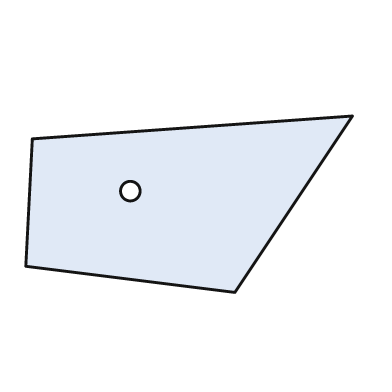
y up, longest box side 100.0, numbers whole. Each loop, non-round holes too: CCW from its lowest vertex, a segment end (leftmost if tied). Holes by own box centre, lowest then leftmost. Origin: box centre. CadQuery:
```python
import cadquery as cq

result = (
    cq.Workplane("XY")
    .moveTo(14.0, -27.0)
    .lineTo(50.0, 27.0)
    .lineTo(-48.0, 20.0)
    .lineTo(-50.0, -19.0)
    .close()
    .moveTo(-18.0, 4.0)
    .circle(3.0)
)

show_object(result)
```